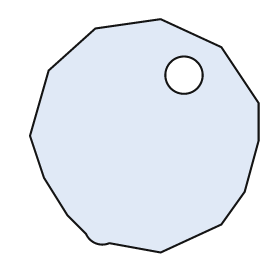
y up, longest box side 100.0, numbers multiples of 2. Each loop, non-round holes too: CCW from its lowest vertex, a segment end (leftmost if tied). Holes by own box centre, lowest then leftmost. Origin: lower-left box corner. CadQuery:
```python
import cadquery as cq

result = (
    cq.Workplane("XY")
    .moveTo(56.0, 0.0)
    .lineTo(82.0, 12.0)
    .lineTo(92.0, 26.0)
    .lineTo(98.0, 48.0)
    .lineTo(98.0, 64.0)
    .lineTo(82.0, 88.0)
    .lineTo(56.0, 100.0)
    .lineTo(28.0, 96.0)
    .lineTo(8.0, 78.0)
    .lineTo(0.0, 50.0)
    .lineTo(6.0, 32.0)
    .lineTo(16.0, 16.0)
    .lineTo(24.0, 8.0)
    .threePointArc((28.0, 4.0), (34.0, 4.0))
    .close()
    .moveTo(66.0, 76.0)
    .circle(8.0)
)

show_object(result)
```